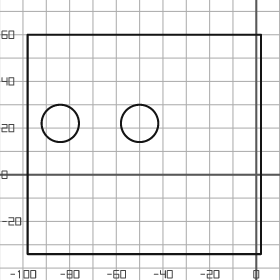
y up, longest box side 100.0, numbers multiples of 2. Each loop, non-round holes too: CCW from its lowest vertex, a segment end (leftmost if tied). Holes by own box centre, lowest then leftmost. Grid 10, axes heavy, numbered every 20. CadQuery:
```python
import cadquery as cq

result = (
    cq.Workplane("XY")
    .moveTo(-98.0, -34.0)
    .lineTo(2.0, -34.0)
    .lineTo(2.0, 60.0)
    .lineTo(-98.0, 60.0)
    .close()
    .moveTo(-84.0, 22.0)
    .circle(8.0)
    .moveTo(-50.0, 22.0)
    .circle(8.0)
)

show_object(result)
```